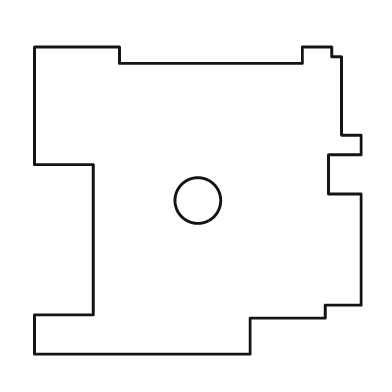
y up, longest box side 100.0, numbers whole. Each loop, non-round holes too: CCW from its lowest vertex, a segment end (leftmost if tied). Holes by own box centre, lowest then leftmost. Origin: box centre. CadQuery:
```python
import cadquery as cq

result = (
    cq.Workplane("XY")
    .moveTo(-50.0, -47.0)
    .lineTo(16.0, -47.0)
    .lineTo(16.0, -36.0)
    .lineTo(39.0, -36.0)
    .lineTo(39.0, -32.0)
    .lineTo(50.0, -32.0)
    .lineTo(50.0, 2.0)
    .lineTo(40.0, 2.0)
    .lineTo(40.0, 14.0)
    .lineTo(50.0, 14.0)
    .lineTo(50.0, 20.0)
    .lineTo(44.0, 20.0)
    .lineTo(44.0, 44.0)
    .lineTo(41.0, 44.0)
    .lineTo(41.0, 47.0)
    .lineTo(32.0, 47.0)
    .lineTo(32.0, 42.0)
    .lineTo(-24.0, 42.0)
    .lineTo(-24.0, 47.0)
    .lineTo(-50.0, 47.0)
    .lineTo(-50.0, 11.0)
    .lineTo(-32.0, 11.0)
    .lineTo(-32.0, -35.0)
    .lineTo(-50.0, -35.0)
    .close()
    .moveTo(0.0, 0.0)
    .circle(7.0)
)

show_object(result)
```